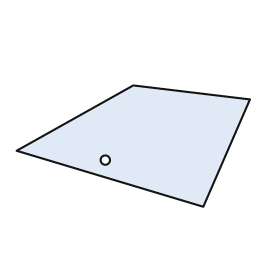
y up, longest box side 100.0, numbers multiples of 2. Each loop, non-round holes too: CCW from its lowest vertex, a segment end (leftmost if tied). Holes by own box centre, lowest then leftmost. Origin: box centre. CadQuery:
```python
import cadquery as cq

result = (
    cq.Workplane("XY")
    .moveTo(30.0, -26.0)
    .lineTo(50.0, 20.0)
    .lineTo(0.0, 26.0)
    .lineTo(-50.0, -2.0)
    .close()
    .moveTo(-12.0, -6.0)
    .circle(2.0)
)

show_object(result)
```